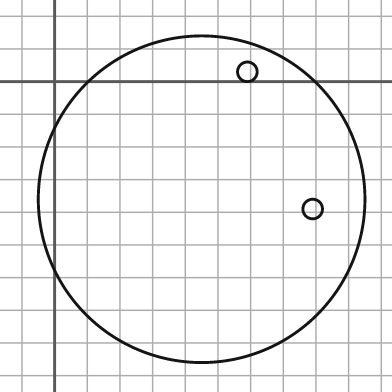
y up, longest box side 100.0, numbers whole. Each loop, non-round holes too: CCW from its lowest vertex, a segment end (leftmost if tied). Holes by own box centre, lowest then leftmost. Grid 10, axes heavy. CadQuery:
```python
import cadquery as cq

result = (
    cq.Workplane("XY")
    .moveTo(45.0, -36.0)
    .circle(50.0)
    .moveTo(79.0, -39.0)
    .circle(3.0)
    .moveTo(59.0, 3.0)
    .circle(3.0)
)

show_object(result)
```